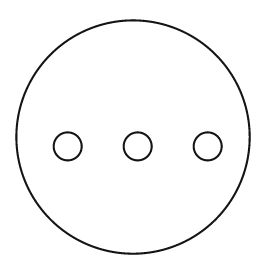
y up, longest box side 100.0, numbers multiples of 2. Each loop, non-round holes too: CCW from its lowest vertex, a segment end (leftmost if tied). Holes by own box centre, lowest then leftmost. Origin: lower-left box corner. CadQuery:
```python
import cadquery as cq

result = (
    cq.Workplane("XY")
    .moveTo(50.0, 50.0)
    .circle(50.0)
    .moveTo(22.0, 46.0)
    .circle(6.0)
    .moveTo(52.0, 46.0)
    .circle(6.0)
    .moveTo(82.0, 46.0)
    .circle(6.0)
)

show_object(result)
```